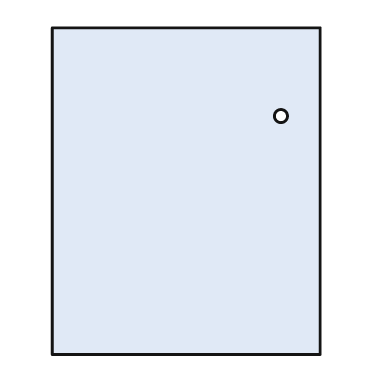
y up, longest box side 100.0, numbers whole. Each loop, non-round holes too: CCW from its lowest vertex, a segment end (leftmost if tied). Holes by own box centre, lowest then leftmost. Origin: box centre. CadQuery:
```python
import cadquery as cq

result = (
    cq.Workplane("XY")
    .moveTo(-41.0, -50.0)
    .lineTo(41.0, -50.0)
    .lineTo(41.0, 50.0)
    .lineTo(-41.0, 50.0)
    .close()
    .moveTo(29.0, 23.0)
    .circle(2.0)
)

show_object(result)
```